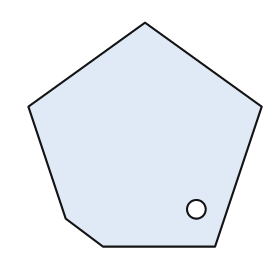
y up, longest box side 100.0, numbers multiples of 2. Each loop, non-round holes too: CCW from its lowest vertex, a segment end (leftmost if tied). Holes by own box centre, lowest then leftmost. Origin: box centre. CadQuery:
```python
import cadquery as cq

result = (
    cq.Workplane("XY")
    .moveTo(-18.0, -48.0)
    .lineTo(30.0, -48.0)
    .lineTo(50.0, 12.0)
    .lineTo(0.0, 48.0)
    .lineTo(-50.0, 12.0)
    .lineTo(-34.0, -36.0)
    .close()
    .moveTo(22.0, -32.0)
    .circle(4.0)
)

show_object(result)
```